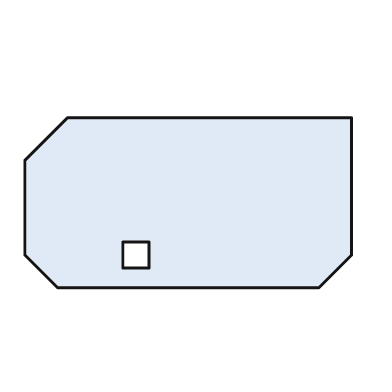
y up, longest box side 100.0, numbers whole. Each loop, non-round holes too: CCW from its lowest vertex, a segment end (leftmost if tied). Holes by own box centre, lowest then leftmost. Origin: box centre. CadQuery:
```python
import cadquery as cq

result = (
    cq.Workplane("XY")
    .moveTo(-40.0, -26.0)
    .lineTo(40.0, -26.0)
    .lineTo(50.0, -16.0)
    .lineTo(50.0, 26.0)
    .lineTo(-37.0, 26.0)
    .lineTo(-50.0, 13.0)
    .lineTo(-50.0, -16.0)
    .close()
    .moveTo(-20.0, -20.0)
    .lineTo(-12.0, -20.0)
    .lineTo(-12.0, -12.0)
    .lineTo(-20.0, -12.0)
    .close()
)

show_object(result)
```